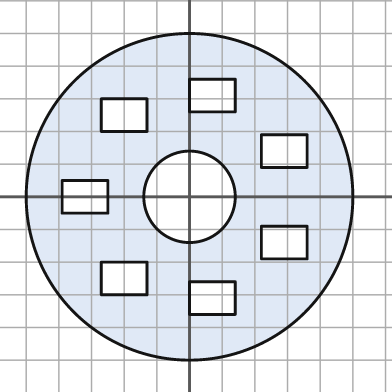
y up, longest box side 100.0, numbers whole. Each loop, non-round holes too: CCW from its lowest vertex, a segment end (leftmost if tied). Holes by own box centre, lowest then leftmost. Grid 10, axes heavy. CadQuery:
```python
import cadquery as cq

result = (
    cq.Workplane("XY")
    .moveTo(0.0, 0.0)
    .circle(50.0)
    .moveTo(0.0, -36.0)
    .lineTo(14.0, -36.0)
    .lineTo(14.0, -26.0)
    .lineTo(0.0, -26.0)
    .close()
    .moveTo(-27.0, -30.0)
    .lineTo(-13.0, -30.0)
    .lineTo(-13.0, -20.0)
    .lineTo(-27.0, -20.0)
    .close()
    .moveTo(22.0, -19.0)
    .lineTo(36.0, -19.0)
    .lineTo(36.0, -9.0)
    .lineTo(22.0, -9.0)
    .close()
    .moveTo(-39.0, -5.0)
    .lineTo(-25.0, -5.0)
    .lineTo(-25.0, 5.0)
    .lineTo(-39.0, 5.0)
    .close()
    .moveTo(0.0, 0.0)
    .circle(14.0)
    .moveTo(22.0, 9.0)
    .lineTo(36.0, 9.0)
    .lineTo(36.0, 19.0)
    .lineTo(22.0, 19.0)
    .close()
    .moveTo(-27.0, 20.0)
    .lineTo(-13.0, 20.0)
    .lineTo(-13.0, 30.0)
    .lineTo(-27.0, 30.0)
    .close()
    .moveTo(0.0, 26.0)
    .lineTo(14.0, 26.0)
    .lineTo(14.0, 36.0)
    .lineTo(0.0, 36.0)
    .close()
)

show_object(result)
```